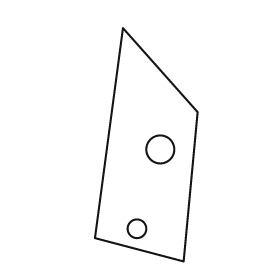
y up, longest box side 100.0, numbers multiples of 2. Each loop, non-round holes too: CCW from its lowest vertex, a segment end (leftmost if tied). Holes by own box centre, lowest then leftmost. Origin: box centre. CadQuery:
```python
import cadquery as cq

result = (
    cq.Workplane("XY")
    .moveTo(16.0, -50.0)
    .lineTo(22.0, 14.0)
    .lineTo(-10.0, 50.0)
    .lineTo(-22.0, -40.0)
    .close()
    .moveTo(-4.0, -36.0)
    .circle(4.0)
    .moveTo(6.0, -2.0)
    .circle(6.0)
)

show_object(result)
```